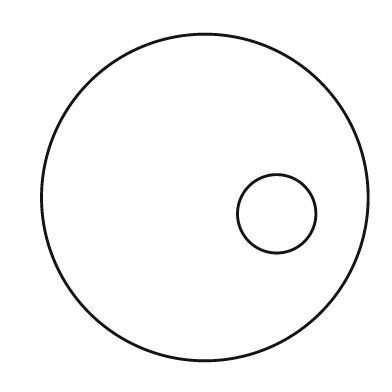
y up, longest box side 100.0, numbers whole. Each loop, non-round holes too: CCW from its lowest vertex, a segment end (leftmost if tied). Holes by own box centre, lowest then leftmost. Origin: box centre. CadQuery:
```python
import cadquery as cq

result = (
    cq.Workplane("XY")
    .moveTo(0.0, 0.0)
    .circle(50.0)
    .moveTo(22.0, -5.0)
    .circle(12.0)
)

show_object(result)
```